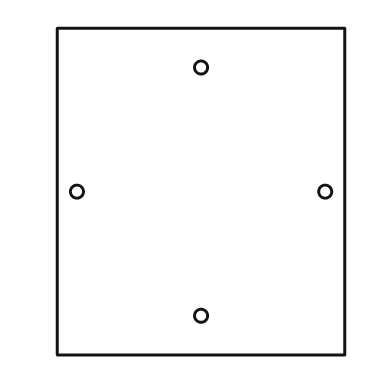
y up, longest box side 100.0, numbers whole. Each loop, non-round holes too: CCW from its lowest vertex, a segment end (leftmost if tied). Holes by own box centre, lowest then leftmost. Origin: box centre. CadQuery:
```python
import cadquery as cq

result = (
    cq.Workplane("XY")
    .moveTo(-44.0, -50.0)
    .lineTo(44.0, -50.0)
    .lineTo(44.0, 50.0)
    .lineTo(-44.0, 50.0)
    .close()
    .moveTo(0.0, -38.0)
    .circle(2.0)
    .moveTo(-38.0, 0.0)
    .circle(2.0)
    .moveTo(38.0, 0.0)
    .circle(2.0)
    .moveTo(0.0, 38.0)
    .circle(2.0)
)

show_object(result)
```